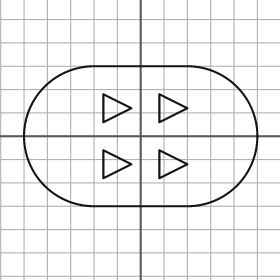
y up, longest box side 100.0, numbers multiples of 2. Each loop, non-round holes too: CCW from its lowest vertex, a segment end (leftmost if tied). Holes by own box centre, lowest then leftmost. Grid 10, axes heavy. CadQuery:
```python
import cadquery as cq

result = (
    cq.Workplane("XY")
    .moveTo(-20.0, -30.0)
    .lineTo(20.0, -30.0)
    .threePointArc((50.0, 0.0), (20.0, 30.0))
    .lineTo(-20.0, 30.0)
    .threePointArc((-50.0, 0.0), (-20.0, -30.0))
    .close()
    .moveTo(-16.0, -18.0)
    .lineTo(-4.0, -12.0)
    .lineTo(-16.0, -6.0)
    .close()
    .moveTo(8.0, -18.0)
    .lineTo(20.0, -12.0)
    .lineTo(8.0, -6.0)
    .close()
    .moveTo(-16.0, 6.0)
    .lineTo(-4.0, 12.0)
    .lineTo(-16.0, 18.0)
    .close()
    .moveTo(8.0, 6.0)
    .lineTo(20.0, 12.0)
    .lineTo(8.0, 18.0)
    .close()
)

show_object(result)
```